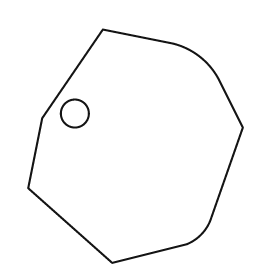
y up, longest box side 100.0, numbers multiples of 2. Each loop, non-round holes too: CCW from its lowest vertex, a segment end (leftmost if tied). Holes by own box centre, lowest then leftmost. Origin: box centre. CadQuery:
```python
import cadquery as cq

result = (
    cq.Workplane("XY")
    .moveTo(-10.0, -50.0)
    .lineTo(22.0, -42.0)
    .threePointArc((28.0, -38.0), (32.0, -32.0))
    .lineTo(46.0, 8.0)
    .lineTo(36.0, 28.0)
    .threePointArc((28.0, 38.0), (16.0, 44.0))
    .lineTo(-14.0, 50.0)
    .lineTo(-40.0, 12.0)
    .lineTo(-46.0, -18.0)
    .close()
    .moveTo(-26.0, 14.0)
    .circle(6.0)
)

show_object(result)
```